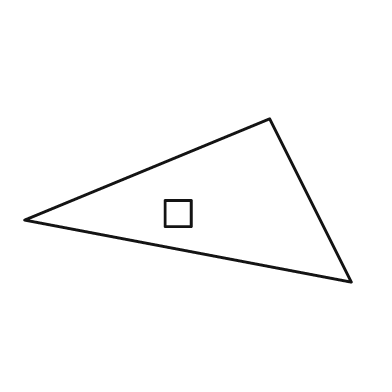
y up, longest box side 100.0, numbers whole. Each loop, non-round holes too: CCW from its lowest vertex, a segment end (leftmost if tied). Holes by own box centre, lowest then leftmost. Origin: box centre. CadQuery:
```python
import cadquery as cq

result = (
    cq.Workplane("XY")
    .moveTo(50.0, -25.0)
    .lineTo(25.0, 25.0)
    .lineTo(-50.0, -6.0)
    .close()
    .moveTo(-7.0, -8.0)
    .lineTo(1.0, -8.0)
    .lineTo(1.0, 0.0)
    .lineTo(-7.0, 0.0)
    .close()
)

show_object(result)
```